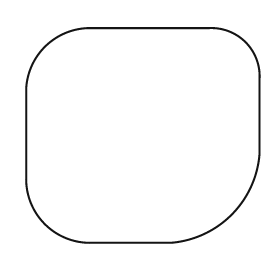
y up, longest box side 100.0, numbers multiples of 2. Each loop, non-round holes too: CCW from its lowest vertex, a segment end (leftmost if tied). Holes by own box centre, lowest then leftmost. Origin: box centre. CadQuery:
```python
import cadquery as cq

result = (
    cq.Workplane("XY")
    .moveTo(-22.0, -46.0)
    .lineTo(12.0, -46.0)
    .threePointArc((38.0, -34.0), (50.0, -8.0))
    .lineTo(50.0, 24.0)
    .threePointArc((44.0, 40.0), (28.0, 46.0))
    .lineTo(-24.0, 46.0)
    .threePointArc((-42.0, 38.0), (-50.0, 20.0))
    .lineTo(-50.0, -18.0)
    .threePointArc((-42.0, -38.0), (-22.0, -46.0))
    .close()
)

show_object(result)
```